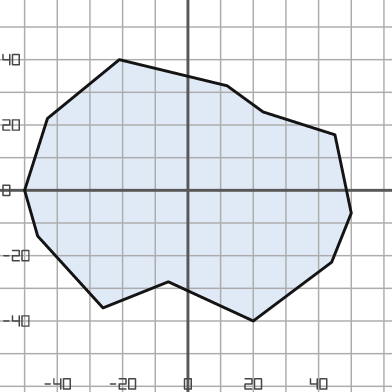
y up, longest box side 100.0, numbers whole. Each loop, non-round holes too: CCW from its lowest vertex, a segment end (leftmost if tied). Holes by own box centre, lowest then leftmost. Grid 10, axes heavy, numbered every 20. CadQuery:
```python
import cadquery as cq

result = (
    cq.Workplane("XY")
    .moveTo(20.0, -40.0)
    .lineTo(44.0, -22.0)
    .lineTo(50.0, -7.0)
    .lineTo(45.0, 17.0)
    .lineTo(23.0, 24.0)
    .lineTo(12.0, 32.0)
    .lineTo(-21.0, 40.0)
    .lineTo(-43.0, 22.0)
    .lineTo(-50.0, 0.0)
    .lineTo(-46.0, -14.0)
    .lineTo(-26.0, -36.0)
    .lineTo(-6.0, -28.0)
    .close()
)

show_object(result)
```